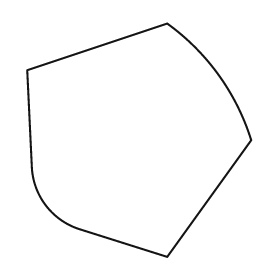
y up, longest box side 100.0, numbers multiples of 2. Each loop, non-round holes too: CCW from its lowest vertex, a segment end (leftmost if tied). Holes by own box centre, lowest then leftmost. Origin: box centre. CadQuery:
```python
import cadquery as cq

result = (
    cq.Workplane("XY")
    .moveTo(12.0, -50.0)
    .lineTo(48.0, 0.0)
    .threePointArc((34.0, 28.0), (12.0, 50.0))
    .lineTo(-48.0, 30.0)
    .lineTo(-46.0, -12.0)
    .threePointArc((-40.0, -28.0), (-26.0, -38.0))
    .close()
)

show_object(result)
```